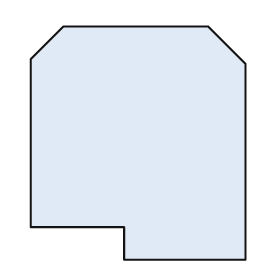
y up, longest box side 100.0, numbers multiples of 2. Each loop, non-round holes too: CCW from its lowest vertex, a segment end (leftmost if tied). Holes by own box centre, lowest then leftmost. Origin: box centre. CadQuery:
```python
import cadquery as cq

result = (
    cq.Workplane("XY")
    .moveTo(-6.0, -50.0)
    .lineTo(46.0, -50.0)
    .lineTo(46.0, 34.0)
    .lineTo(30.0, 50.0)
    .lineTo(-32.0, 50.0)
    .lineTo(-46.0, 36.0)
    .lineTo(-46.0, -36.0)
    .lineTo(-6.0, -36.0)
    .close()
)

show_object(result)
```